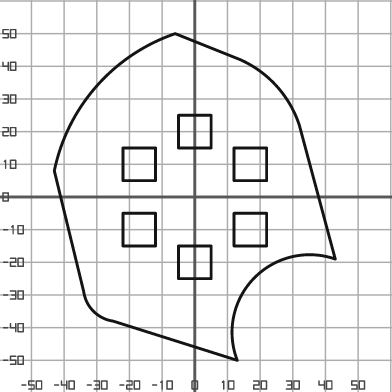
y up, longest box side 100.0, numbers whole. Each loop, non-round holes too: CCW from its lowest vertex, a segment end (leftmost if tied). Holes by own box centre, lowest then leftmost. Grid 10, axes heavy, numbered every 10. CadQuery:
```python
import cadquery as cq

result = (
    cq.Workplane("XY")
    .moveTo(13.0, -50.0)
    .threePointArc((18.0, -25.0), (43.0, -19.0))
    .lineTo(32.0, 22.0)
    .threePointArc((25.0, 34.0), (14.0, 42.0))
    .lineTo(-6.0, 50.0)
    .threePointArc((-30.0, 34.0), (-43.0, 8.0))
    .lineTo(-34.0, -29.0)
    .threePointArc((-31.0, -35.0), (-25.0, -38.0))
    .close()
    .moveTo(-5.0, -25.0)
    .lineTo(5.0, -25.0)
    .lineTo(5.0, -15.0)
    .lineTo(-5.0, -15.0)
    .close()
    .moveTo(-22.0, -15.0)
    .lineTo(-12.0, -15.0)
    .lineTo(-12.0, -5.0)
    .lineTo(-22.0, -5.0)
    .close()
    .moveTo(12.0, -15.0)
    .lineTo(22.0, -15.0)
    .lineTo(22.0, -5.0)
    .lineTo(12.0, -5.0)
    .close()
    .moveTo(-22.0, 5.0)
    .lineTo(-12.0, 5.0)
    .lineTo(-12.0, 15.0)
    .lineTo(-22.0, 15.0)
    .close()
    .moveTo(12.0, 5.0)
    .lineTo(22.0, 5.0)
    .lineTo(22.0, 15.0)
    .lineTo(12.0, 15.0)
    .close()
    .moveTo(-5.0, 15.0)
    .lineTo(5.0, 15.0)
    .lineTo(5.0, 25.0)
    .lineTo(-5.0, 25.0)
    .close()
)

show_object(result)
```